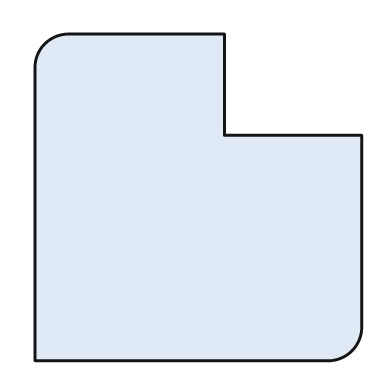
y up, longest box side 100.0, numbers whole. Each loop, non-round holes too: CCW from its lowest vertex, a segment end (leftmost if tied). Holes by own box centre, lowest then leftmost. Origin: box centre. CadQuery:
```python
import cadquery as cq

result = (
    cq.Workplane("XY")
    .moveTo(-50.0, -50.0)
    .lineTo(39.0, -50.0)
    .threePointArc((47.0, -47.0), (50.0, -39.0))
    .lineTo(50.0, 19.0)
    .lineTo(8.0, 19.0)
    .lineTo(8.0, 50.0)
    .lineTo(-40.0, 50.0)
    .threePointArc((-47.0, 47.0), (-50.0, 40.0))
    .close()
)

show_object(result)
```